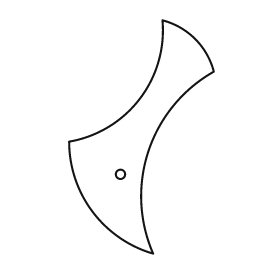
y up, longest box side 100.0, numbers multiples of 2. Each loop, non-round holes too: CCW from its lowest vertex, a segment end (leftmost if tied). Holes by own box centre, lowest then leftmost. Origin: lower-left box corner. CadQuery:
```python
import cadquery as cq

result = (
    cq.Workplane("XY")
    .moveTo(36.0, 0.0)
    .threePointArc((34.0, 44.0), (62.0, 78.0))
    .threePointArc((54.0, 92.0), (40.0, 100.0))
    .threePointArc((30.0, 66.0), (0.0, 48.0))
    .threePointArc((10.0, 18.0), (36.0, 0.0))
    .close()
    .moveTo(22.0, 34.0)
    .circle(2.0)
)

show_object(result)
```